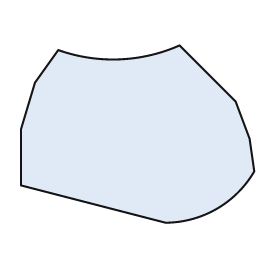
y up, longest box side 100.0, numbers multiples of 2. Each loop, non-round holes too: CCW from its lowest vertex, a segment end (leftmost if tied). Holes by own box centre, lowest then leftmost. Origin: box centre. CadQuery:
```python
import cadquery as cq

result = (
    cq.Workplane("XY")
    .moveTo(12.0, -38.0)
    .threePointArc((34.0, -32.0), (50.0, -16.0))
    .lineTo(48.0, -2.0)
    .lineTo(42.0, 14.0)
    .lineTo(18.0, 38.0)
    .threePointArc((-8.0, 32.0), (-34.0, 36.0))
    .lineTo(-44.0, 22.0)
    .lineTo(-50.0, 2.0)
    .lineTo(-50.0, -22.0)
    .close()
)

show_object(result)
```